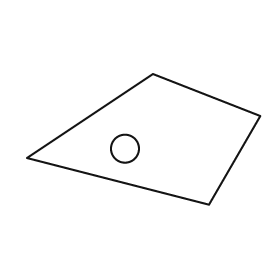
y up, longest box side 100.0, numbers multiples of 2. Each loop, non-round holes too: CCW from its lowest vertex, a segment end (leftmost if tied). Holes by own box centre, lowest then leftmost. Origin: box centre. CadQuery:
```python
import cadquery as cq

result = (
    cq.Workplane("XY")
    .moveTo(28.0, -28.0)
    .lineTo(50.0, 10.0)
    .lineTo(4.0, 28.0)
    .lineTo(-50.0, -8.0)
    .close()
    .moveTo(-8.0, -4.0)
    .circle(6.0)
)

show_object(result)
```